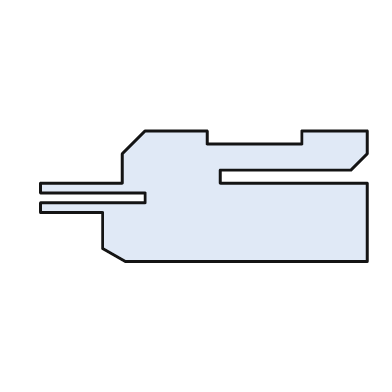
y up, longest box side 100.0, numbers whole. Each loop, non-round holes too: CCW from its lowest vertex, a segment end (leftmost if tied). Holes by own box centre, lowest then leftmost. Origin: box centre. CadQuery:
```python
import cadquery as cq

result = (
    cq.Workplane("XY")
    .moveTo(-24.0, -20.0)
    .lineTo(50.0, -20.0)
    .lineTo(50.0, 4.0)
    .lineTo(5.0, 4.0)
    .lineTo(5.0, 8.0)
    .lineTo(45.0, 8.0)
    .lineTo(50.0, 13.0)
    .lineTo(50.0, 20.0)
    .lineTo(30.0, 20.0)
    .lineTo(30.0, 16.0)
    .lineTo(1.0, 16.0)
    .lineTo(1.0, 20.0)
    .lineTo(-18.0, 20.0)
    .lineTo(-25.0, 13.0)
    .lineTo(-25.0, 4.0)
    .lineTo(-50.0, 4.0)
    .lineTo(-50.0, 1.0)
    .lineTo(-18.0, 1.0)
    .lineTo(-18.0, -2.0)
    .lineTo(-50.0, -2.0)
    .lineTo(-50.0, -5.0)
    .lineTo(-31.0, -5.0)
    .lineTo(-31.0, -16.0)
    .close()
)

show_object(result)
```